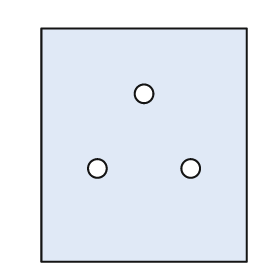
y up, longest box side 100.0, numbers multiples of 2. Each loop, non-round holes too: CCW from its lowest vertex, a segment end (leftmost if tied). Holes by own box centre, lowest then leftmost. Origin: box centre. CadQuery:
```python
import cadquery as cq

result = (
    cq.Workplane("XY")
    .moveTo(-44.0, -50.0)
    .lineTo(44.0, -50.0)
    .lineTo(44.0, 50.0)
    .lineTo(-44.0, 50.0)
    .close()
    .moveTo(-20.0, -10.0)
    .circle(4.0)
    .moveTo(20.0, -10.0)
    .circle(4.0)
    .moveTo(0.0, 22.0)
    .circle(4.0)
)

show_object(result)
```